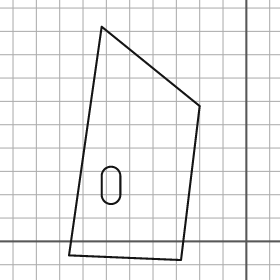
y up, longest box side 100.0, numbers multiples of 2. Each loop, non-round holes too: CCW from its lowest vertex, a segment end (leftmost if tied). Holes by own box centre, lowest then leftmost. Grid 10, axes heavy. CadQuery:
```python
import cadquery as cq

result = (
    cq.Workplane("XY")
    .moveTo(-28.0, -8.0)
    .lineTo(-20.0, 58.0)
    .lineTo(-62.0, 92.0)
    .lineTo(-76.0, -6.0)
    .close()
    .moveTo(-62.0, 20.0)
    .threePointArc((-58.0, 16.0), (-54.0, 20.0))
    .lineTo(-54.0, 28.0)
    .threePointArc((-58.0, 32.0), (-62.0, 28.0))
    .close()
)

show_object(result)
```